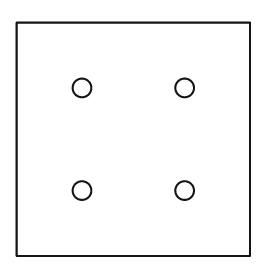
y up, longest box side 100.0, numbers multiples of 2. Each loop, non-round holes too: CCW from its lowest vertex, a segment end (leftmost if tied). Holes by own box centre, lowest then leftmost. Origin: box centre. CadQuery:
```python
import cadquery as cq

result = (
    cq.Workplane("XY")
    .moveTo(-50.0, -50.0)
    .lineTo(50.0, -50.0)
    .lineTo(50.0, 50.0)
    .lineTo(-50.0, 50.0)
    .close()
    .moveTo(-22.0, -22.0)
    .circle(4.0)
    .moveTo(22.0, -22.0)
    .circle(4.0)
    .moveTo(-22.0, 22.0)
    .circle(4.0)
    .moveTo(22.0, 22.0)
    .circle(4.0)
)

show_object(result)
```